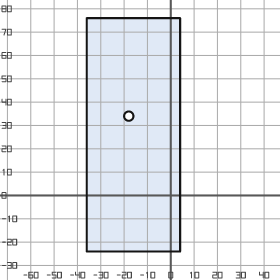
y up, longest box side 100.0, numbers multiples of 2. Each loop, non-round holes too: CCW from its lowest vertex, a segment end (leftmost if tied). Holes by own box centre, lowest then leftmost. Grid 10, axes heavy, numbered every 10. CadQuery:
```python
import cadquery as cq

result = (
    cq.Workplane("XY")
    .moveTo(-36.0, -24.0)
    .lineTo(4.0, -24.0)
    .lineTo(4.0, 76.0)
    .lineTo(-36.0, 76.0)
    .close()
    .moveTo(-18.0, 34.0)
    .circle(2.0)
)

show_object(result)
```